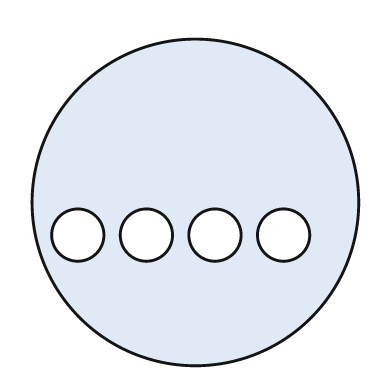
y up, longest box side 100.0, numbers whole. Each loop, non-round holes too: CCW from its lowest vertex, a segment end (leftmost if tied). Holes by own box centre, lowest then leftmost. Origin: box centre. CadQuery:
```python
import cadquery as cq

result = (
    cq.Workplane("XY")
    .moveTo(0.0, 0.0)
    .circle(50.0)
    .moveTo(-36.0, -10.0)
    .circle(8.0)
    .moveTo(-15.0, -10.0)
    .circle(8.0)
    .moveTo(6.0, -10.0)
    .circle(8.0)
    .moveTo(27.0, -10.0)
    .circle(8.0)
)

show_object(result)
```